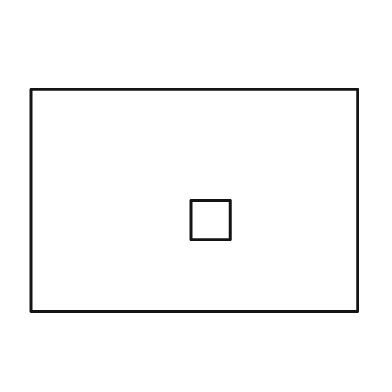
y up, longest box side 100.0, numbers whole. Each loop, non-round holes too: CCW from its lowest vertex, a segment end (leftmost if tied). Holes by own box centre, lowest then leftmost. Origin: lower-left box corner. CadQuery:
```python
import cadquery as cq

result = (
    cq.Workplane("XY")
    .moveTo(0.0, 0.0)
    .lineTo(100.0, 0.0)
    .lineTo(100.0, 68.0)
    .lineTo(0.0, 68.0)
    .close()
    .moveTo(49.0, 22.0)
    .lineTo(61.0, 22.0)
    .lineTo(61.0, 34.0)
    .lineTo(49.0, 34.0)
    .close()
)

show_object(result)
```